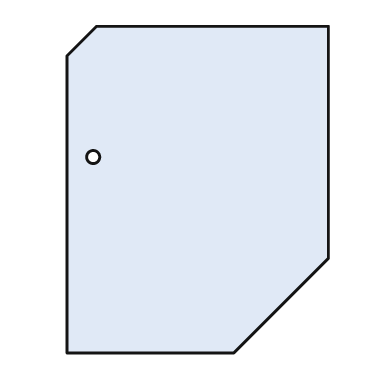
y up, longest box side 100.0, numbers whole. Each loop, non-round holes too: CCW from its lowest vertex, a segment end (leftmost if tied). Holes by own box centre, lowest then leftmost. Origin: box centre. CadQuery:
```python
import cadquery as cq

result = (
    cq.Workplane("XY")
    .moveTo(-40.0, -50.0)
    .lineTo(11.0, -50.0)
    .lineTo(40.0, -21.0)
    .lineTo(40.0, 50.0)
    .lineTo(-31.0, 50.0)
    .lineTo(-40.0, 41.0)
    .close()
    .moveTo(-32.0, 10.0)
    .circle(2.0)
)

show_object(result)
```